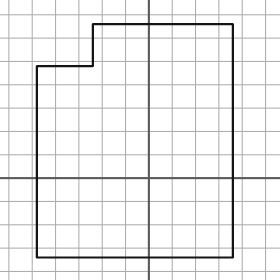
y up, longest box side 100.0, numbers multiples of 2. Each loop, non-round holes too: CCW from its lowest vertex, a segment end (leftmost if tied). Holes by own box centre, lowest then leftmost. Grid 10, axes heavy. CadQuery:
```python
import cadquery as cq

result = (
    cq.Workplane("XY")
    .moveTo(-48.0, -34.0)
    .lineTo(36.0, -34.0)
    .lineTo(36.0, 66.0)
    .lineTo(-24.0, 66.0)
    .lineTo(-24.0, 48.0)
    .lineTo(-48.0, 48.0)
    .close()
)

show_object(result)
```